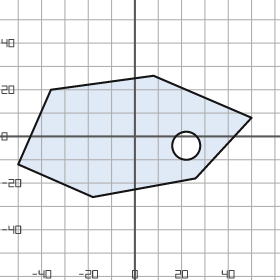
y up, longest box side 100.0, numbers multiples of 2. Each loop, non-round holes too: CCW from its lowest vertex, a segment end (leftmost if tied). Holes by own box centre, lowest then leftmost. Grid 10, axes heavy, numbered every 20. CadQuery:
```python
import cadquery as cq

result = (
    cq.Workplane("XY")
    .moveTo(-18.0, -26.0)
    .lineTo(26.0, -18.0)
    .lineTo(50.0, 8.0)
    .lineTo(8.0, 26.0)
    .lineTo(-36.0, 20.0)
    .lineTo(-50.0, -12.0)
    .close()
    .moveTo(22.0, -4.0)
    .circle(6.0)
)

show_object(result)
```